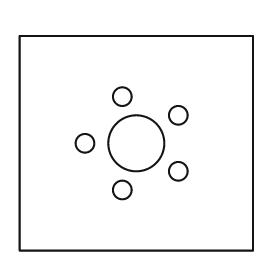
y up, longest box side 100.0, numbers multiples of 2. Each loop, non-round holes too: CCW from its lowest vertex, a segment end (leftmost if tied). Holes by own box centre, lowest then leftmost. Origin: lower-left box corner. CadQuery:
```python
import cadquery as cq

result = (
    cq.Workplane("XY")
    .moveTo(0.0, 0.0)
    .lineTo(100.0, 0.0)
    .lineTo(100.0, 92.0)
    .lineTo(0.0, 92.0)
    .close()
    .moveTo(44.0, 26.0)
    .circle(4.0)
    .moveTo(68.0, 34.0)
    .circle(4.0)
    .moveTo(28.0, 46.0)
    .circle(4.0)
    .moveTo(50.0, 46.0)
    .circle(12.0)
    .moveTo(68.0, 58.0)
    .circle(4.0)
    .moveTo(44.0, 66.0)
    .circle(4.0)
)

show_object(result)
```